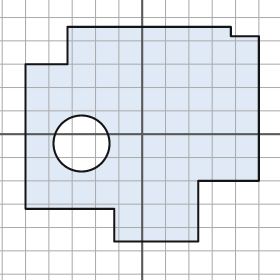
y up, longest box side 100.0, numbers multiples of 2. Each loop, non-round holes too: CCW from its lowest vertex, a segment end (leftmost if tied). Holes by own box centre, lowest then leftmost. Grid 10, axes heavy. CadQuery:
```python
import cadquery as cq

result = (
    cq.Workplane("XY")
    .moveTo(-12.0, -46.0)
    .lineTo(24.0, -46.0)
    .lineTo(24.0, -20.0)
    .lineTo(50.0, -20.0)
    .lineTo(50.0, 42.0)
    .lineTo(38.0, 42.0)
    .lineTo(38.0, 46.0)
    .lineTo(-32.0, 46.0)
    .lineTo(-32.0, 30.0)
    .lineTo(-50.0, 30.0)
    .lineTo(-50.0, -32.0)
    .lineTo(-12.0, -32.0)
    .close()
    .moveTo(-26.0, -4.0)
    .circle(12.0)
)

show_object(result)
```